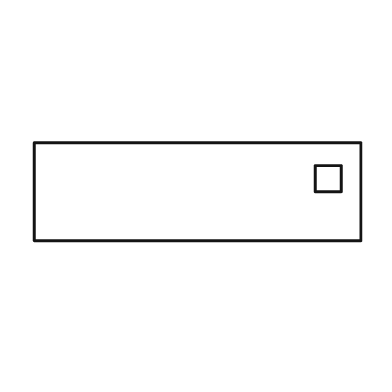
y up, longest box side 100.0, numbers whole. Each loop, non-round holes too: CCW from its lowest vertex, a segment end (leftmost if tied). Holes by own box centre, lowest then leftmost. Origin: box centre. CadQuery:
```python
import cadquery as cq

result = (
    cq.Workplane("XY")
    .moveTo(-50.0, -15.0)
    .lineTo(50.0, -15.0)
    .lineTo(50.0, 15.0)
    .lineTo(-50.0, 15.0)
    .close()
    .moveTo(36.0, 0.0)
    .lineTo(44.0, 0.0)
    .lineTo(44.0, 8.0)
    .lineTo(36.0, 8.0)
    .close()
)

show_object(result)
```